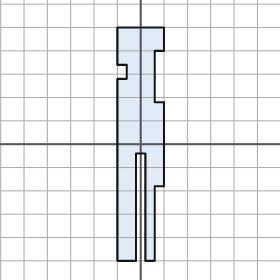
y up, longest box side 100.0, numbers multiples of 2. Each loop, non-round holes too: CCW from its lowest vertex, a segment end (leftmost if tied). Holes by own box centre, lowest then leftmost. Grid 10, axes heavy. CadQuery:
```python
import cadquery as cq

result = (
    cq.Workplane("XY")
    .moveTo(-10.0, -50.0)
    .lineTo(-2.0, -50.0)
    .lineTo(-2.0, -4.0)
    .lineTo(2.0, -4.0)
    .lineTo(2.0, -50.0)
    .lineTo(6.0, -50.0)
    .lineTo(6.0, -18.0)
    .lineTo(10.0, -18.0)
    .lineTo(10.0, 18.0)
    .lineTo(6.0, 18.0)
    .lineTo(6.0, 40.0)
    .lineTo(10.0, 40.0)
    .lineTo(10.0, 50.0)
    .lineTo(-10.0, 50.0)
    .lineTo(-10.0, 34.0)
    .lineTo(-6.0, 34.0)
    .lineTo(-6.0, 28.0)
    .lineTo(-10.0, 28.0)
    .close()
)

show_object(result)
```